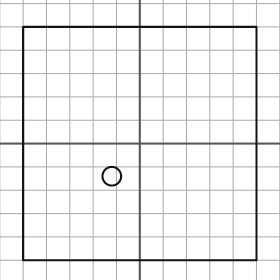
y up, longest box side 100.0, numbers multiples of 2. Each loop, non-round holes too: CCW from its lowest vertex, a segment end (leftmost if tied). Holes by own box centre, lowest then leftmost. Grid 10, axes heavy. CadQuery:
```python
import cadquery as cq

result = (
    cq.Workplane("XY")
    .moveTo(-50.0, -50.0)
    .lineTo(50.0, -50.0)
    .lineTo(50.0, 50.0)
    .lineTo(-50.0, 50.0)
    .close()
    .moveTo(-12.0, -14.0)
    .circle(4.0)
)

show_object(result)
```